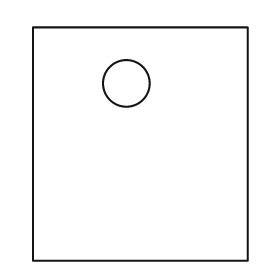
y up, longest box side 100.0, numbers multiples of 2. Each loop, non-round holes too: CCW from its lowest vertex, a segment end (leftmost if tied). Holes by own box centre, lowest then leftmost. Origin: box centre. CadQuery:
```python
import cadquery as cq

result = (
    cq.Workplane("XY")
    .moveTo(-46.0, -50.0)
    .lineTo(46.0, -50.0)
    .lineTo(46.0, 50.0)
    .lineTo(-46.0, 50.0)
    .close()
    .moveTo(-6.0, 26.0)
    .circle(10.0)
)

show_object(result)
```